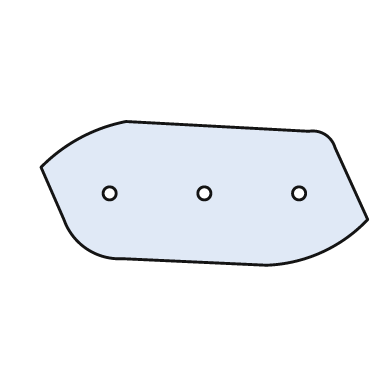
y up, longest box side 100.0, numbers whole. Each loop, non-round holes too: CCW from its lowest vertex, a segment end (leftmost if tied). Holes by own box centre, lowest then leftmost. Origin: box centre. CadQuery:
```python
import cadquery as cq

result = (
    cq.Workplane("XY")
    .moveTo(19.0, -22.0)
    .threePointArc((36.0, -18.0), (50.0, -8.0))
    .lineTo(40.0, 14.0)
    .threePointArc((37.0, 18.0), (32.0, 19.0))
    .lineTo(-24.0, 22.0)
    .threePointArc((-38.0, 17.0), (-50.0, 8.0))
    .lineTo(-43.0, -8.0)
    .threePointArc((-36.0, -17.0), (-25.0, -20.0))
    .close()
    .moveTo(-29.0, 0.0)
    .circle(2.0)
    .moveTo(0.0, 0.0)
    .circle(2.0)
    .moveTo(29.0, 0.0)
    .circle(2.0)
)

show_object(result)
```